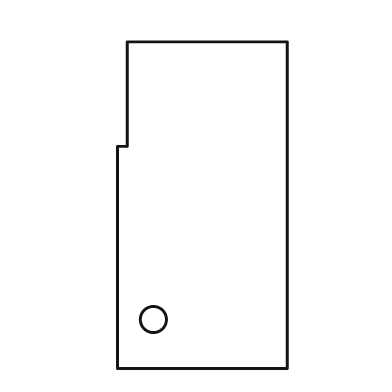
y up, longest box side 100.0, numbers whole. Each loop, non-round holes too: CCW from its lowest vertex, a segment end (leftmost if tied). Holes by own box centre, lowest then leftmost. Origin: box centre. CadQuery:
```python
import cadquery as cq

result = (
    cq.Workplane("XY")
    .moveTo(-26.0, -50.0)
    .lineTo(26.0, -50.0)
    .lineTo(26.0, 50.0)
    .lineTo(-23.0, 50.0)
    .lineTo(-23.0, 18.0)
    .lineTo(-26.0, 18.0)
    .close()
    .moveTo(-15.0, -35.0)
    .circle(4.0)
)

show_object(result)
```